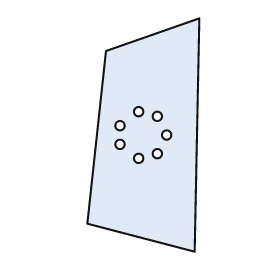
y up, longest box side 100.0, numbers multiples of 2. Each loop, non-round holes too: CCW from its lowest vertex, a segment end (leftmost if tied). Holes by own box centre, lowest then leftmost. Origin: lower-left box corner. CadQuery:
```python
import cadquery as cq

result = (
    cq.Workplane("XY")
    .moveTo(46.0, 0.0)
    .lineTo(48.0, 100.0)
    .lineTo(8.0, 86.0)
    .lineTo(0.0, 12.0)
    .close()
    .moveTo(22.0, 40.0)
    .circle(2.0)
    .moveTo(30.0, 42.0)
    .circle(2.0)
    .moveTo(14.0, 46.0)
    .circle(2.0)
    .moveTo(34.0, 50.0)
    .circle(2.0)
    .moveTo(14.0, 54.0)
    .circle(2.0)
    .moveTo(30.0, 58.0)
    .circle(2.0)
    .moveTo(22.0, 60.0)
    .circle(2.0)
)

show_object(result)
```